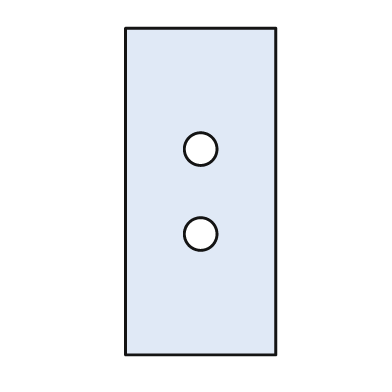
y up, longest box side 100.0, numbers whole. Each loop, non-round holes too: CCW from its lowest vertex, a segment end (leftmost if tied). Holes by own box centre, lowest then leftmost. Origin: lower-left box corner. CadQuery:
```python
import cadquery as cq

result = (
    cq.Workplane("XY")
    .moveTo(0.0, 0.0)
    .lineTo(46.0, 0.0)
    .lineTo(46.0, 100.0)
    .lineTo(0.0, 100.0)
    .close()
    .moveTo(23.0, 37.0)
    .circle(5.0)
    .moveTo(23.0, 63.0)
    .circle(5.0)
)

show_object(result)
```